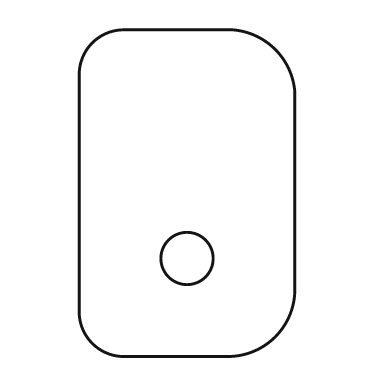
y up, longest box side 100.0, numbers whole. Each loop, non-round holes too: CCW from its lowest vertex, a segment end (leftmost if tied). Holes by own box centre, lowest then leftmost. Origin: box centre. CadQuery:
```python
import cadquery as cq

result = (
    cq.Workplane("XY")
    .moveTo(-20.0, -50.0)
    .lineTo(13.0, -50.0)
    .threePointArc((27.0, -44.0), (33.0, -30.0))
    .lineTo(33.0, 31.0)
    .threePointArc((27.0, 44.0), (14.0, 50.0))
    .lineTo(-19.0, 50.0)
    .threePointArc((-29.0, 46.0), (-33.0, 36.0))
    .lineTo(-33.0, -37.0)
    .threePointArc((-29.0, -46.0), (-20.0, -50.0))
    .close()
    .moveTo(0.0, -20.0)
    .circle(8.0)
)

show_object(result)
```